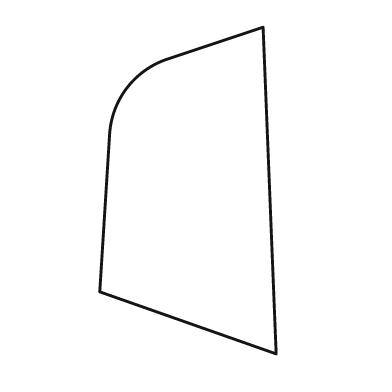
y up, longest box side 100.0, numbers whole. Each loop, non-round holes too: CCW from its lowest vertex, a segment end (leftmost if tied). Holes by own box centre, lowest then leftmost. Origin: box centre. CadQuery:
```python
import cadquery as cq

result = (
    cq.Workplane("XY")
    .moveTo(27.0, -50.0)
    .lineTo(23.0, 50.0)
    .lineTo(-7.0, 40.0)
    .threePointArc((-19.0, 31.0), (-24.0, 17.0))
    .lineTo(-27.0, -31.0)
    .close()
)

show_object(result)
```